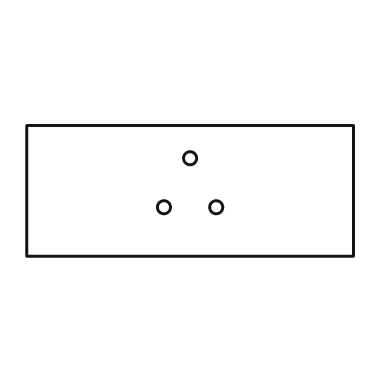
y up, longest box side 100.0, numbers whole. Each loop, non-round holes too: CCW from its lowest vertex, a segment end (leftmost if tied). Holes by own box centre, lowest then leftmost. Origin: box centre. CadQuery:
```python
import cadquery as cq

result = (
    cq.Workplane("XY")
    .moveTo(-50.0, -20.0)
    .lineTo(50.0, -20.0)
    .lineTo(50.0, 20.0)
    .lineTo(-50.0, 20.0)
    .close()
    .moveTo(-8.0, -5.0)
    .circle(2.0)
    .moveTo(8.0, -5.0)
    .circle(2.0)
    .moveTo(0.0, 10.0)
    .circle(2.0)
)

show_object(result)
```